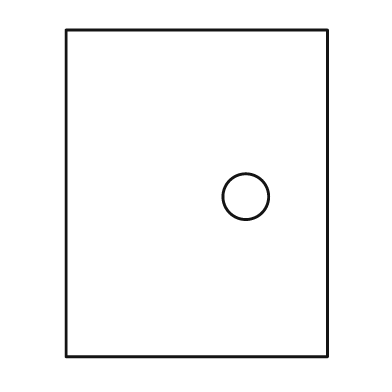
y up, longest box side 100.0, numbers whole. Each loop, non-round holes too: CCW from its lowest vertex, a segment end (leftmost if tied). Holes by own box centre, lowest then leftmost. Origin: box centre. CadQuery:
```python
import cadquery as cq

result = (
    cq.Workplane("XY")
    .moveTo(-40.0, -50.0)
    .lineTo(40.0, -50.0)
    .lineTo(40.0, 50.0)
    .lineTo(-40.0, 50.0)
    .close()
    .moveTo(15.0, -1.0)
    .circle(7.0)
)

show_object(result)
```